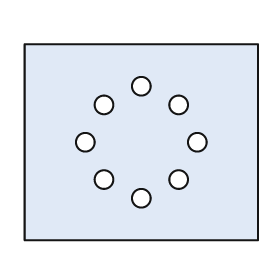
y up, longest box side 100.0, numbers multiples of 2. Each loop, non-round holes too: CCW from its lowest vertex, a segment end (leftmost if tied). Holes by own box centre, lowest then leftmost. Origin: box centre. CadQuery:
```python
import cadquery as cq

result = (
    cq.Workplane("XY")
    .moveTo(-50.0, -42.0)
    .lineTo(50.0, -42.0)
    .lineTo(50.0, 42.0)
    .lineTo(-50.0, 42.0)
    .close()
    .moveTo(0.0, -24.0)
    .circle(4.0)
    .moveTo(-16.0, -16.0)
    .circle(4.0)
    .moveTo(16.0, -16.0)
    .circle(4.0)
    .moveTo(-24.0, 0.0)
    .circle(4.0)
    .moveTo(24.0, 0.0)
    .circle(4.0)
    .moveTo(-16.0, 16.0)
    .circle(4.0)
    .moveTo(16.0, 16.0)
    .circle(4.0)
    .moveTo(0.0, 24.0)
    .circle(4.0)
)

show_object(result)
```